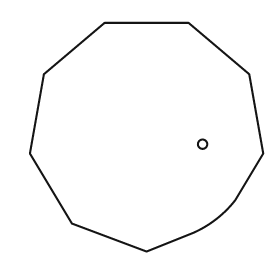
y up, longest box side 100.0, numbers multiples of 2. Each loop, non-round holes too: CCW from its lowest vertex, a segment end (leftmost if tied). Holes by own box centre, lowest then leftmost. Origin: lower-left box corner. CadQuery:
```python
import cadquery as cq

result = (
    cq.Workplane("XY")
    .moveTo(50.0, 0.0)
    .lineTo(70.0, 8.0)
    .threePointArc((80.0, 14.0), (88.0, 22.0))
    .lineTo(100.0, 42.0)
    .lineTo(94.0, 76.0)
    .lineTo(68.0, 98.0)
    .lineTo(32.0, 98.0)
    .lineTo(6.0, 76.0)
    .lineTo(0.0, 42.0)
    .lineTo(18.0, 12.0)
    .close()
    .moveTo(74.0, 46.0)
    .circle(2.0)
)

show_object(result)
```